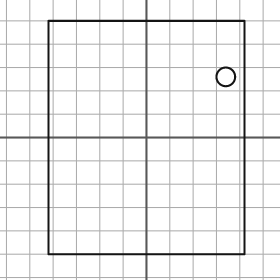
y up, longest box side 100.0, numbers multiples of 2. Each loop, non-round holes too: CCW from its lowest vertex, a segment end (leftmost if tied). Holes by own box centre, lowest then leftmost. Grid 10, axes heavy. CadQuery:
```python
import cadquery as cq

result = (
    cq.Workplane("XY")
    .moveTo(-42.0, -50.0)
    .lineTo(42.0, -50.0)
    .lineTo(42.0, 50.0)
    .lineTo(-42.0, 50.0)
    .close()
    .moveTo(34.0, 26.0)
    .circle(4.0)
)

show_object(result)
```